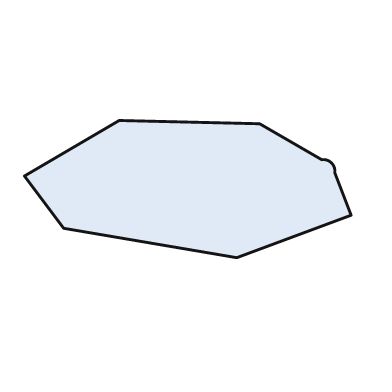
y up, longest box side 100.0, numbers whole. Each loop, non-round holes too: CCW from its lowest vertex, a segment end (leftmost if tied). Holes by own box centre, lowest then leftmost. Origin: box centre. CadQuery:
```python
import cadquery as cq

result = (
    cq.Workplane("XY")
    .moveTo(15.0, -21.0)
    .lineTo(50.0, -8.0)
    .lineTo(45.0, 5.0)
    .threePointArc((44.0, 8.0), (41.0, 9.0))
    .lineTo(22.0, 20.0)
    .lineTo(-21.0, 21.0)
    .lineTo(-50.0, 4.0)
    .lineTo(-38.0, -12.0)
    .close()
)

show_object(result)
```